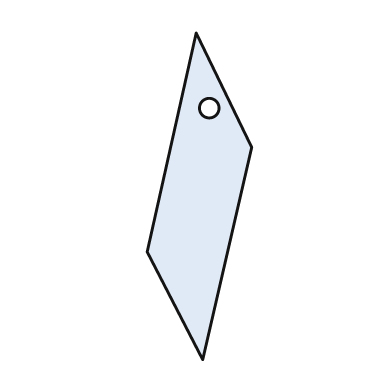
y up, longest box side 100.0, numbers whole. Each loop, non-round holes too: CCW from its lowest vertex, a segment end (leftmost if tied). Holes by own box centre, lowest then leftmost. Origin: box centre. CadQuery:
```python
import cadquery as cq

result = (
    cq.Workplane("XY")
    .moveTo(1.0, -50.0)
    .lineTo(16.0, 15.0)
    .lineTo(-1.0, 50.0)
    .lineTo(-16.0, -17.0)
    .close()
    .moveTo(3.0, 27.0)
    .circle(3.0)
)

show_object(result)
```